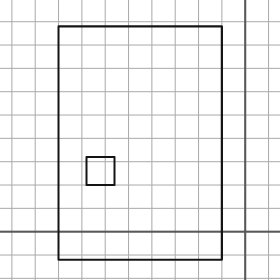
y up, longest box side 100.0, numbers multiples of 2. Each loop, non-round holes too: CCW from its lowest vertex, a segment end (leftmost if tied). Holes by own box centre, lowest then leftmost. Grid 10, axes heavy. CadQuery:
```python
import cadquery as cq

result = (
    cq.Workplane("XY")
    .moveTo(-80.0, -12.0)
    .lineTo(-10.0, -12.0)
    .lineTo(-10.0, 88.0)
    .lineTo(-80.0, 88.0)
    .close()
    .moveTo(-68.0, 20.0)
    .lineTo(-56.0, 20.0)
    .lineTo(-56.0, 32.0)
    .lineTo(-68.0, 32.0)
    .close()
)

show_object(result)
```